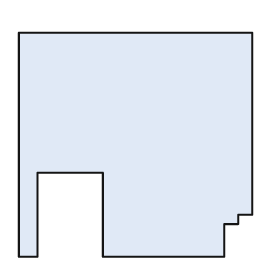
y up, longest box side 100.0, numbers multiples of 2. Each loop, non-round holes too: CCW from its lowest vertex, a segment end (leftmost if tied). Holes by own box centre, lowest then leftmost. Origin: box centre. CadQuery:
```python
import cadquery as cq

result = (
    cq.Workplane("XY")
    .moveTo(-50.0, -48.0)
    .lineTo(-42.0, -48.0)
    .lineTo(-42.0, -12.0)
    .lineTo(-14.0, -12.0)
    .lineTo(-14.0, -48.0)
    .lineTo(38.0, -48.0)
    .lineTo(38.0, -34.0)
    .lineTo(44.0, -34.0)
    .lineTo(44.0, -30.0)
    .lineTo(50.0, -30.0)
    .lineTo(50.0, 48.0)
    .lineTo(-50.0, 48.0)
    .close()
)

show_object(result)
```